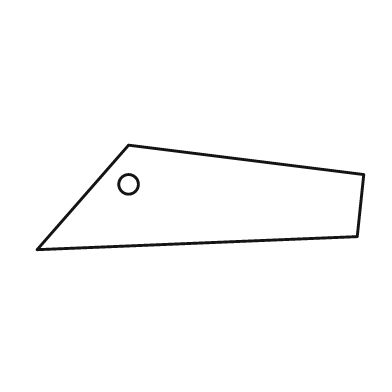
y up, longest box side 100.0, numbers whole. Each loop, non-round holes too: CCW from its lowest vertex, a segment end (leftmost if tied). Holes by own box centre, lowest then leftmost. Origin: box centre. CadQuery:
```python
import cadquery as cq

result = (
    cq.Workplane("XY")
    .moveTo(-50.0, -16.0)
    .lineTo(48.0, -12.0)
    .lineTo(50.0, 7.0)
    .lineTo(-22.0, 16.0)
    .close()
    .moveTo(-22.0, 4.0)
    .circle(3.0)
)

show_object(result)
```